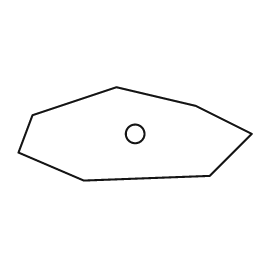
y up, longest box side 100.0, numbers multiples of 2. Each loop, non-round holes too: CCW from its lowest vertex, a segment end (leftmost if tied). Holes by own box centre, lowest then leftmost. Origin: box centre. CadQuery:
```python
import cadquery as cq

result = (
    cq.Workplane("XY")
    .moveTo(-22.0, -20.0)
    .lineTo(32.0, -18.0)
    .lineTo(50.0, 0.0)
    .lineTo(26.0, 12.0)
    .lineTo(-8.0, 20.0)
    .lineTo(-44.0, 8.0)
    .lineTo(-50.0, -8.0)
    .close()
    .moveTo(0.0, 0.0)
    .circle(4.0)
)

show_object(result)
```